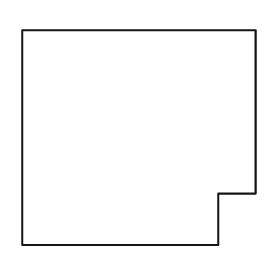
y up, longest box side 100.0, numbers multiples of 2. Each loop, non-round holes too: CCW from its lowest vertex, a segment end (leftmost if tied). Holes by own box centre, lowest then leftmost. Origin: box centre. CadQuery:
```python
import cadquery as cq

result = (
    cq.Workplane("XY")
    .moveTo(-50.0, -46.0)
    .lineTo(34.0, -46.0)
    .lineTo(34.0, -24.0)
    .lineTo(50.0, -24.0)
    .lineTo(50.0, 46.0)
    .lineTo(-50.0, 46.0)
    .close()
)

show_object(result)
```